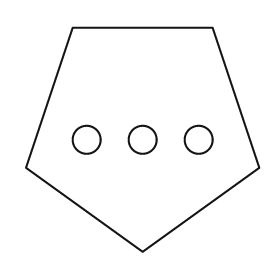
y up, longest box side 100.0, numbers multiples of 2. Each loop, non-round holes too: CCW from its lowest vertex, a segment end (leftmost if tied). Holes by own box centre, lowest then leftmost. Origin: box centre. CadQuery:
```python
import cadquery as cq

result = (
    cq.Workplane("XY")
    .moveTo(0.0, -48.0)
    .lineTo(50.0, -12.0)
    .lineTo(30.0, 48.0)
    .lineTo(-30.0, 48.0)
    .lineTo(-50.0, -12.0)
    .close()
    .moveTo(-24.0, 0.0)
    .circle(6.0)
    .moveTo(0.0, 0.0)
    .circle(6.0)
    .moveTo(24.0, 0.0)
    .circle(6.0)
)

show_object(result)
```